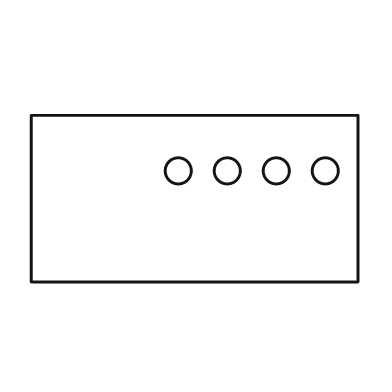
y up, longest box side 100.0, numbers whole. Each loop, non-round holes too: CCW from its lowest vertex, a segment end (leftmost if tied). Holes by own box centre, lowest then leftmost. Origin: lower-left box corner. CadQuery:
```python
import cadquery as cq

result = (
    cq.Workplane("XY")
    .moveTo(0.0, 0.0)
    .lineTo(100.0, 0.0)
    .lineTo(100.0, 51.0)
    .lineTo(0.0, 51.0)
    .close()
    .moveTo(45.0, 34.0)
    .circle(4.0)
    .moveTo(60.0, 34.0)
    .circle(4.0)
    .moveTo(75.0, 34.0)
    .circle(4.0)
    .moveTo(90.0, 34.0)
    .circle(4.0)
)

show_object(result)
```